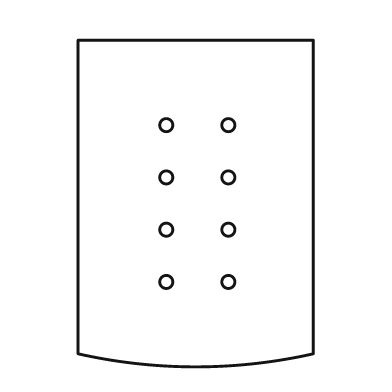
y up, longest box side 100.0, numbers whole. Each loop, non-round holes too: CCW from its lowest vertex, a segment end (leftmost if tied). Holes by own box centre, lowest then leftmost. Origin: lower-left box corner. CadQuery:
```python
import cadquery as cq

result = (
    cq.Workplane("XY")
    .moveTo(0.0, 4.0)
    .threePointArc((36.0, 0.0), (72.0, 4.0))
    .lineTo(72.0, 100.0)
    .lineTo(0.0, 100.0)
    .close()
    .moveTo(27.0, 26.0)
    .circle(2.0)
    .moveTo(46.0, 26.0)
    .circle(2.0)
    .moveTo(27.0, 42.0)
    .circle(2.0)
    .moveTo(46.0, 42.0)
    .circle(2.0)
    .moveTo(27.0, 58.0)
    .circle(2.0)
    .moveTo(46.0, 58.0)
    .circle(2.0)
    .moveTo(27.0, 74.0)
    .circle(2.0)
    .moveTo(46.0, 74.0)
    .circle(2.0)
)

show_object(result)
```